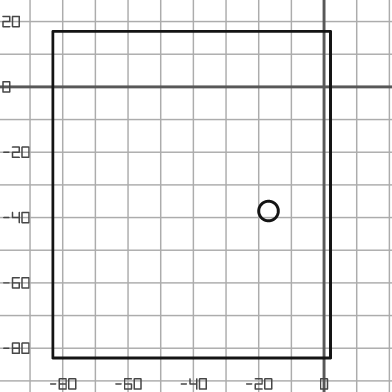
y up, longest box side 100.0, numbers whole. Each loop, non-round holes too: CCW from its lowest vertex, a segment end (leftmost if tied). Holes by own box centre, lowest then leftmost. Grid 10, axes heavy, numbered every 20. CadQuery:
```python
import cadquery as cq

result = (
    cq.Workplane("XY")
    .moveTo(-83.0, -83.0)
    .lineTo(2.0, -83.0)
    .lineTo(2.0, 17.0)
    .lineTo(-83.0, 17.0)
    .close()
    .moveTo(-17.0, -38.0)
    .circle(3.0)
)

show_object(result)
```